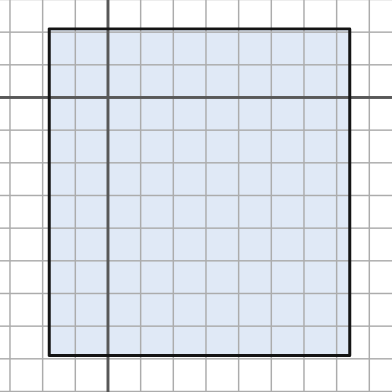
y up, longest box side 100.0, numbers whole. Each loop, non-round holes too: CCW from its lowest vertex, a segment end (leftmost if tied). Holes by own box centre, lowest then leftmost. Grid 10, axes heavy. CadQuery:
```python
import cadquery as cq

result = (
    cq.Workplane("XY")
    .moveTo(-18.0, -79.0)
    .lineTo(74.0, -79.0)
    .lineTo(74.0, 21.0)
    .lineTo(-18.0, 21.0)
    .close()
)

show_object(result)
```